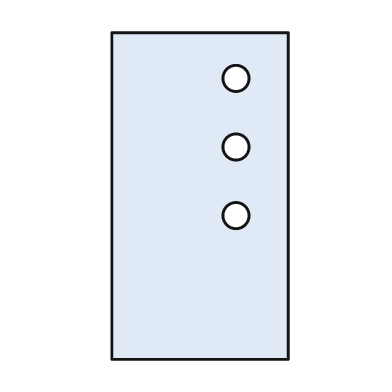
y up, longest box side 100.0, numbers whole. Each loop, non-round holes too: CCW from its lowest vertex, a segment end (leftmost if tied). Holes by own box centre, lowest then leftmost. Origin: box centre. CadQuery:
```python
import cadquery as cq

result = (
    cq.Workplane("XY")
    .moveTo(-27.0, -50.0)
    .lineTo(27.0, -50.0)
    .lineTo(27.0, 50.0)
    .lineTo(-27.0, 50.0)
    .close()
    .moveTo(11.0, -6.0)
    .circle(4.0)
    .moveTo(11.0, 15.0)
    .circle(4.0)
    .moveTo(11.0, 36.0)
    .circle(4.0)
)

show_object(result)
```